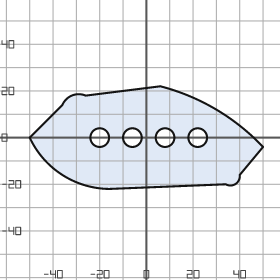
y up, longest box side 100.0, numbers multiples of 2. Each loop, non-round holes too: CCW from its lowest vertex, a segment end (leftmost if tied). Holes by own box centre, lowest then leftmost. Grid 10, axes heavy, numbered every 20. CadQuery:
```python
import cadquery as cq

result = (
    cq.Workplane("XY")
    .moveTo(-16.0, -22.0)
    .lineTo(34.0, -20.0)
    .threePointArc((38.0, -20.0), (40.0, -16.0))
    .lineTo(50.0, -4.0)
    .threePointArc((30.0, 12.0), (6.0, 22.0))
    .lineTo(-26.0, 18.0)
    .threePointArc((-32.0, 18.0), (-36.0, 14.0))
    .lineTo(-50.0, 0.0)
    .threePointArc((-36.0, -16.0), (-16.0, -22.0))
    .close()
    .moveTo(-20.0, 0.0)
    .circle(4.0)
    .moveTo(-6.0, 0.0)
    .circle(4.0)
    .moveTo(8.0, 0.0)
    .circle(4.0)
    .moveTo(22.0, 0.0)
    .circle(4.0)
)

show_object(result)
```